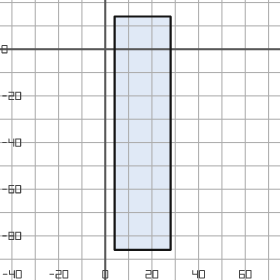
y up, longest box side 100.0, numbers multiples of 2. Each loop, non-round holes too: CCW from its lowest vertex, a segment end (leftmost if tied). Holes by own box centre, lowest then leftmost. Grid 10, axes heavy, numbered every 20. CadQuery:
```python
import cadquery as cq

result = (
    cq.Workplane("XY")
    .moveTo(4.0, -86.0)
    .lineTo(28.0, -86.0)
    .lineTo(28.0, 14.0)
    .lineTo(4.0, 14.0)
    .close()
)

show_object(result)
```